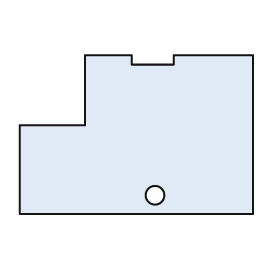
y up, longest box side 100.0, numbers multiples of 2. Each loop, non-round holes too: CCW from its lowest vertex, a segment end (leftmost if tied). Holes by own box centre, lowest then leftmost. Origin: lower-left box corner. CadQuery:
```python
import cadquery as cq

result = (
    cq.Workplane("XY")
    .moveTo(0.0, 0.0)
    .lineTo(100.0, 0.0)
    .lineTo(100.0, 68.0)
    .lineTo(66.0, 68.0)
    .lineTo(66.0, 64.0)
    .lineTo(48.0, 64.0)
    .lineTo(48.0, 68.0)
    .lineTo(28.0, 68.0)
    .lineTo(28.0, 38.0)
    .lineTo(0.0, 38.0)
    .close()
    .moveTo(58.0, 8.0)
    .circle(4.0)
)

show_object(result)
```